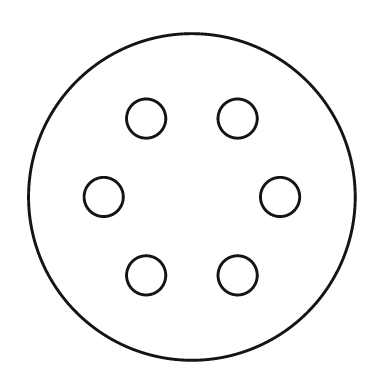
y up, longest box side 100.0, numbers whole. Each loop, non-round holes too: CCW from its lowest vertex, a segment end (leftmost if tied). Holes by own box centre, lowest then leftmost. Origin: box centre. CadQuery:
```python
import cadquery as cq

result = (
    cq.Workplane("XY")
    .moveTo(0.0, 0.0)
    .circle(50.0)
    .moveTo(-14.0, -24.0)
    .circle(6.0)
    .moveTo(14.0, -24.0)
    .circle(6.0)
    .moveTo(-27.0, 0.0)
    .circle(6.0)
    .moveTo(27.0, 0.0)
    .circle(6.0)
    .moveTo(-14.0, 24.0)
    .circle(6.0)
    .moveTo(14.0, 24.0)
    .circle(6.0)
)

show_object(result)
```